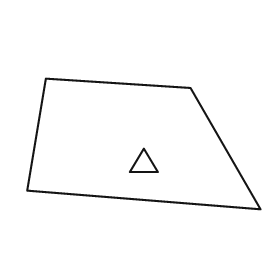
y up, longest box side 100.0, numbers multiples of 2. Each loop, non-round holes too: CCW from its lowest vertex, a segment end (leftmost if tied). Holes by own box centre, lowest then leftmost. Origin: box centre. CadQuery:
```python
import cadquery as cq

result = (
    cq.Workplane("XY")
    .moveTo(50.0, -28.0)
    .lineTo(20.0, 24.0)
    .lineTo(-42.0, 28.0)
    .lineTo(-50.0, -20.0)
    .close()
    .moveTo(-6.0, -12.0)
    .lineTo(6.0, -12.0)
    .lineTo(0.0, -2.0)
    .close()
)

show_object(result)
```